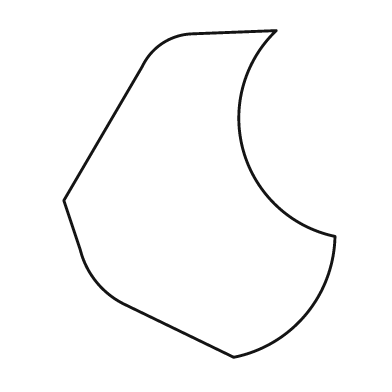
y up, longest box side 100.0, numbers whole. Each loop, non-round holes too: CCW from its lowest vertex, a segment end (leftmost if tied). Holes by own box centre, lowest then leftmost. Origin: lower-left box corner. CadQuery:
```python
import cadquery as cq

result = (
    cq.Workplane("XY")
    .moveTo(52.0, 0.0)
    .threePointArc((74.0, 13.0), (83.0, 37.0))
    .threePointArc((55.0, 63.0), (65.0, 100.0))
    .lineTo(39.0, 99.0)
    .threePointArc((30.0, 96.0), (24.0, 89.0))
    .lineTo(0.0, 48.0)
    .lineTo(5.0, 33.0)
    .threePointArc((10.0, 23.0), (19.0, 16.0))
    .close()
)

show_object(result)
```